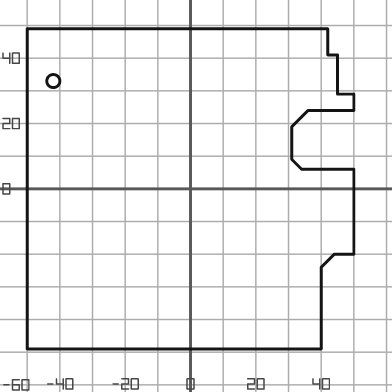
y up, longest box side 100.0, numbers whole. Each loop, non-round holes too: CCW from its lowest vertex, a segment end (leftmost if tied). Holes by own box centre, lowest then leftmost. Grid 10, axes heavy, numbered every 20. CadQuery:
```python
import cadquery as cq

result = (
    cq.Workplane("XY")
    .moveTo(-50.0, -49.0)
    .lineTo(40.0, -49.0)
    .lineTo(40.0, -24.0)
    .lineTo(44.0, -20.0)
    .lineTo(50.0, -20.0)
    .lineTo(50.0, 6.0)
    .lineTo(34.0, 6.0)
    .lineTo(31.0, 9.0)
    .lineTo(31.0, 19.0)
    .lineTo(36.0, 24.0)
    .lineTo(50.0, 24.0)
    .lineTo(50.0, 29.0)
    .lineTo(45.0, 29.0)
    .lineTo(45.0, 41.0)
    .lineTo(42.0, 41.0)
    .lineTo(42.0, 49.0)
    .lineTo(-50.0, 49.0)
    .close()
    .moveTo(-42.0, 33.0)
    .circle(2.0)
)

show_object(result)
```